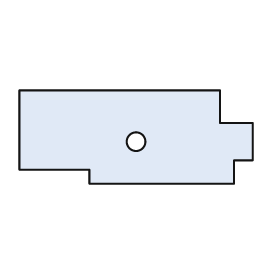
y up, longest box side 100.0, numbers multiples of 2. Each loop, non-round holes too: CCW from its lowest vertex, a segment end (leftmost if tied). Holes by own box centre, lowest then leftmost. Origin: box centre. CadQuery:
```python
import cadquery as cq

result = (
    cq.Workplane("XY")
    .moveTo(-20.0, -20.0)
    .lineTo(42.0, -20.0)
    .lineTo(42.0, -10.0)
    .lineTo(50.0, -10.0)
    .lineTo(50.0, 6.0)
    .lineTo(36.0, 6.0)
    .lineTo(36.0, 20.0)
    .lineTo(-50.0, 20.0)
    .lineTo(-50.0, -14.0)
    .lineTo(-20.0, -14.0)
    .close()
    .moveTo(0.0, -2.0)
    .circle(4.0)
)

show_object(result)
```